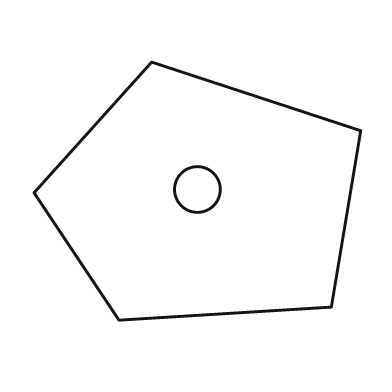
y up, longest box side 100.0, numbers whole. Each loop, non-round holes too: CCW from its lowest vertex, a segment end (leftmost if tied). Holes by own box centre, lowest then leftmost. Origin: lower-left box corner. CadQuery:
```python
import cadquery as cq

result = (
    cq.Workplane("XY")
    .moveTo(26.0, 0.0)
    .lineTo(91.0, 4.0)
    .lineTo(100.0, 58.0)
    .lineTo(36.0, 79.0)
    .lineTo(0.0, 39.0)
    .close()
    .moveTo(50.0, 40.0)
    .circle(7.0)
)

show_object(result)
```